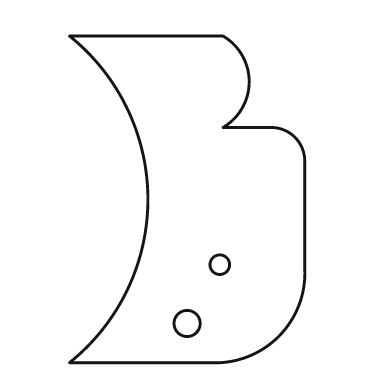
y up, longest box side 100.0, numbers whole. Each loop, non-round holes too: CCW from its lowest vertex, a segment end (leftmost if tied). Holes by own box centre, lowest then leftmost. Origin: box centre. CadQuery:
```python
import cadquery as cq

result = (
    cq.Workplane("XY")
    .moveTo(-36.0, -50.0)
    .lineTo(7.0, -50.0)
    .threePointArc((28.0, -42.0), (36.0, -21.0))
    .lineTo(36.0, 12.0)
    .threePointArc((33.0, 19.0), (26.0, 22.0))
    .lineTo(11.0, 22.0)
    .threePointArc((19.0, 36.0), (11.0, 50.0))
    .lineTo(-36.0, 50.0)
    .threePointArc((-12.0, 0.0), (-36.0, -50.0))
    .close()
    .moveTo(0.0, -38.0)
    .circle(4.0)
    .moveTo(10.0, -20.0)
    .circle(3.0)
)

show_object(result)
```